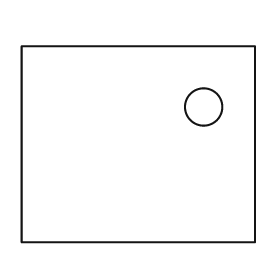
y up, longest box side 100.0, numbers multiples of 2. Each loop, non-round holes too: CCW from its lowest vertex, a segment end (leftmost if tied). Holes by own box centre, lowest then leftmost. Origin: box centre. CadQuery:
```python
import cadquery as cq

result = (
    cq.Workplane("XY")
    .moveTo(-50.0, -42.0)
    .lineTo(50.0, -42.0)
    .lineTo(50.0, 42.0)
    .lineTo(-50.0, 42.0)
    .close()
    .moveTo(28.0, 16.0)
    .circle(8.0)
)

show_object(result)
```